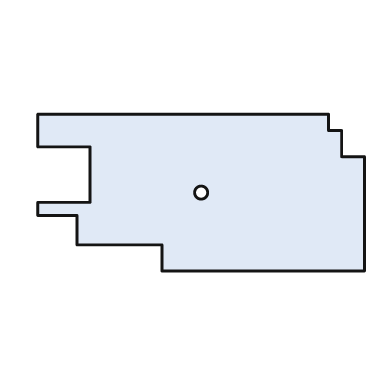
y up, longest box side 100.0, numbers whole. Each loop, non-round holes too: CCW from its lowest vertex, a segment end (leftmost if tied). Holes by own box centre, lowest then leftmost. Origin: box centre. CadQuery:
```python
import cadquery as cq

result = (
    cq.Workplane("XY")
    .moveTo(-12.0, -24.0)
    .lineTo(50.0, -24.0)
    .lineTo(50.0, 11.0)
    .lineTo(43.0, 11.0)
    .lineTo(43.0, 19.0)
    .lineTo(39.0, 19.0)
    .lineTo(39.0, 24.0)
    .lineTo(-50.0, 24.0)
    .lineTo(-50.0, 14.0)
    .lineTo(-34.0, 14.0)
    .lineTo(-34.0, -3.0)
    .lineTo(-50.0, -3.0)
    .lineTo(-50.0, -7.0)
    .lineTo(-38.0, -7.0)
    .lineTo(-38.0, -16.0)
    .lineTo(-12.0, -16.0)
    .close()
    .moveTo(0.0, 0.0)
    .circle(2.0)
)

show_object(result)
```